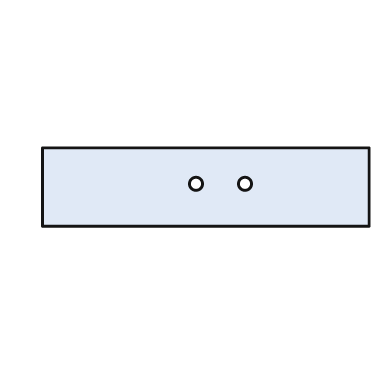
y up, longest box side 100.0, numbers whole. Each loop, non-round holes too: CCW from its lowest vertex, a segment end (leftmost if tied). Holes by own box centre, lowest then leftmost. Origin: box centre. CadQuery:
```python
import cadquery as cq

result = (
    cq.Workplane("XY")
    .moveTo(-50.0, -12.0)
    .lineTo(50.0, -12.0)
    .lineTo(50.0, 12.0)
    .lineTo(-50.0, 12.0)
    .close()
    .moveTo(-3.0, 1.0)
    .circle(2.0)
    .moveTo(12.0, 1.0)
    .circle(2.0)
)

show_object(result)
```